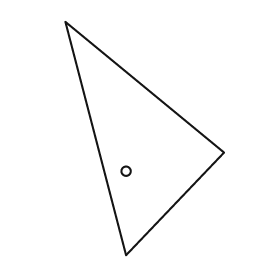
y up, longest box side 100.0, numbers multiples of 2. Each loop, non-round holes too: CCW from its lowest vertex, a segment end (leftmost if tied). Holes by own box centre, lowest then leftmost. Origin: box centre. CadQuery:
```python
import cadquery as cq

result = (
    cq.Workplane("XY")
    .moveTo(-8.0, -50.0)
    .lineTo(34.0, -6.0)
    .lineTo(-34.0, 50.0)
    .close()
    .moveTo(-8.0, -14.0)
    .circle(2.0)
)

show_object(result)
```